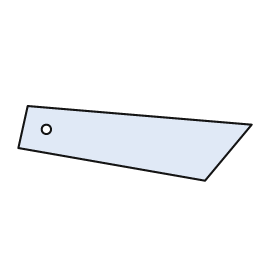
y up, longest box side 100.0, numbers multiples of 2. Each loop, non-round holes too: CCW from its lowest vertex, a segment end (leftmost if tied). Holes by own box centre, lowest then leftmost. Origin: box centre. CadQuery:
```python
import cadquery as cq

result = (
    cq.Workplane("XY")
    .moveTo(30.0, -16.0)
    .lineTo(50.0, 8.0)
    .lineTo(-46.0, 16.0)
    .lineTo(-50.0, -2.0)
    .close()
    .moveTo(-38.0, 6.0)
    .circle(2.0)
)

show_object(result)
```